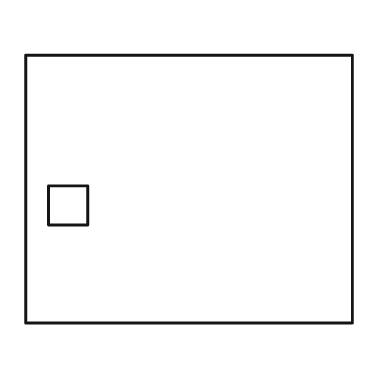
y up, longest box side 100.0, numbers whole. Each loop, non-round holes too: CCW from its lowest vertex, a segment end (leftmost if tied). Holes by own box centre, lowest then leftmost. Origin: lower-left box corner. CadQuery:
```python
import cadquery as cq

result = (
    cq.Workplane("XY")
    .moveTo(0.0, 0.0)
    .lineTo(100.0, 0.0)
    .lineTo(100.0, 82.0)
    .lineTo(0.0, 82.0)
    .close()
    .moveTo(7.0, 30.0)
    .lineTo(19.0, 30.0)
    .lineTo(19.0, 42.0)
    .lineTo(7.0, 42.0)
    .close()
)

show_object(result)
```